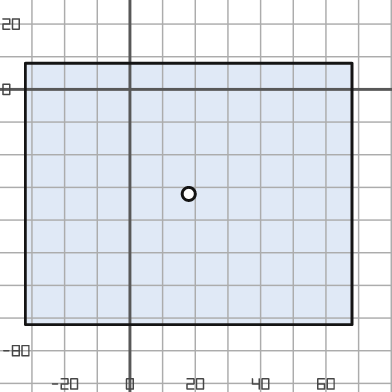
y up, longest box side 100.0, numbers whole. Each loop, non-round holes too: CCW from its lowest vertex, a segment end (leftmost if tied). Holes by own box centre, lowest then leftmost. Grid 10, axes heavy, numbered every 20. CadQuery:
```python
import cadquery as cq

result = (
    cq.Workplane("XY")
    .moveTo(-32.0, -72.0)
    .lineTo(68.0, -72.0)
    .lineTo(68.0, 8.0)
    .lineTo(-32.0, 8.0)
    .close()
    .moveTo(18.0, -32.0)
    .circle(2.0)
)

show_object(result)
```